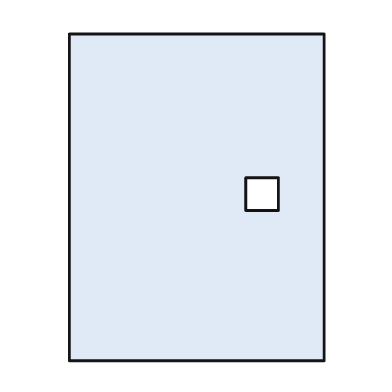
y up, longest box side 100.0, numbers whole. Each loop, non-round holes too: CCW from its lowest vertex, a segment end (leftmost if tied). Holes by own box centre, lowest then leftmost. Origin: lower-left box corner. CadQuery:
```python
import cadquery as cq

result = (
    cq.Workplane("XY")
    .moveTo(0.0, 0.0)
    .lineTo(78.0, 0.0)
    .lineTo(78.0, 100.0)
    .lineTo(0.0, 100.0)
    .close()
    .moveTo(54.0, 46.0)
    .lineTo(64.0, 46.0)
    .lineTo(64.0, 56.0)
    .lineTo(54.0, 56.0)
    .close()
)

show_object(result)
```